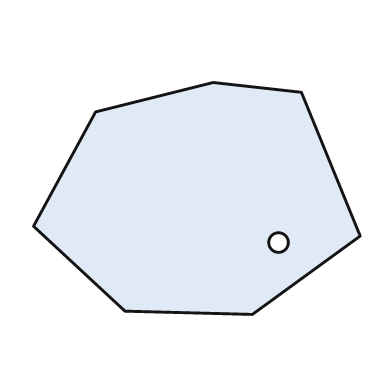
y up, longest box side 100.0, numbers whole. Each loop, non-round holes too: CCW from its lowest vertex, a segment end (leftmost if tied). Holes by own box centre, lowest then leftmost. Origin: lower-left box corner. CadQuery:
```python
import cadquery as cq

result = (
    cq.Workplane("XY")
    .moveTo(67.0, 0.0)
    .lineTo(100.0, 24.0)
    .lineTo(82.0, 68.0)
    .lineTo(55.0, 71.0)
    .lineTo(19.0, 62.0)
    .lineTo(0.0, 27.0)
    .lineTo(28.0, 1.0)
    .close()
    .moveTo(75.0, 22.0)
    .circle(3.0)
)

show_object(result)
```